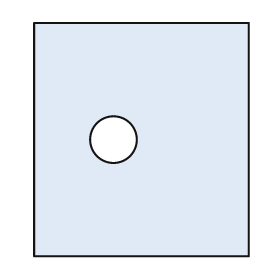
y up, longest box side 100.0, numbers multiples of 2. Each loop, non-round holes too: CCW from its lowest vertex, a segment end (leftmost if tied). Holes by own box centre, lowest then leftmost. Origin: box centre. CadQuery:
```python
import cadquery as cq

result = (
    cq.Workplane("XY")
    .moveTo(-46.0, -50.0)
    .lineTo(46.0, -50.0)
    .lineTo(46.0, 50.0)
    .lineTo(-46.0, 50.0)
    .close()
    .moveTo(-12.0, 0.0)
    .circle(10.0)
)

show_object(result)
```